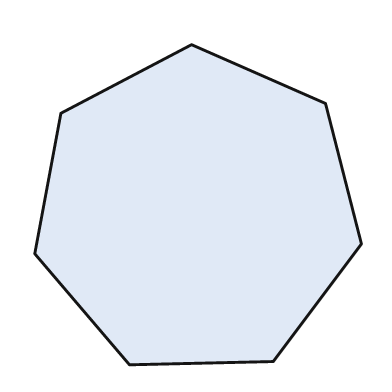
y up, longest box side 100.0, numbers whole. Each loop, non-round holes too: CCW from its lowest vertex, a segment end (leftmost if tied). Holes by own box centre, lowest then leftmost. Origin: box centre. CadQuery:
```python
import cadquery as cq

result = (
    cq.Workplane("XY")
    .moveTo(-21.0, -49.0)
    .lineTo(23.0, -48.0)
    .lineTo(50.0, -12.0)
    .lineTo(39.0, 31.0)
    .lineTo(-2.0, 49.0)
    .lineTo(-42.0, 28.0)
    .lineTo(-50.0, -15.0)
    .close()
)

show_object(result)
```